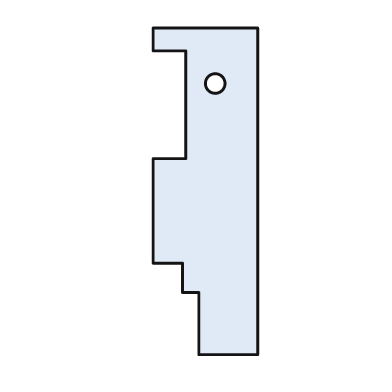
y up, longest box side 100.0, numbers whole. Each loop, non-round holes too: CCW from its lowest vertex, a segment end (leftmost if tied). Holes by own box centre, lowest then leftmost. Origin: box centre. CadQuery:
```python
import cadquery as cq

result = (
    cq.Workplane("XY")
    .moveTo(-2.0, -50.0)
    .lineTo(16.0, -50.0)
    .lineTo(16.0, 50.0)
    .lineTo(-16.0, 50.0)
    .lineTo(-16.0, 43.0)
    .lineTo(-6.0, 43.0)
    .lineTo(-6.0, 10.0)
    .lineTo(-16.0, 10.0)
    .lineTo(-16.0, -22.0)
    .lineTo(-7.0, -22.0)
    .lineTo(-7.0, -31.0)
    .lineTo(-2.0, -31.0)
    .close()
    .moveTo(3.0, 33.0)
    .circle(3.0)
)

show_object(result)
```